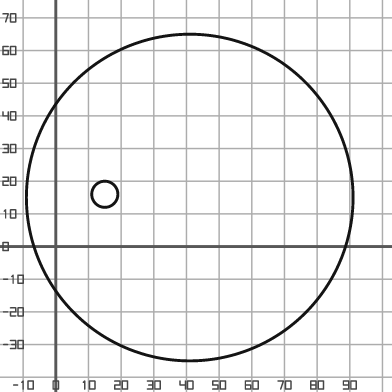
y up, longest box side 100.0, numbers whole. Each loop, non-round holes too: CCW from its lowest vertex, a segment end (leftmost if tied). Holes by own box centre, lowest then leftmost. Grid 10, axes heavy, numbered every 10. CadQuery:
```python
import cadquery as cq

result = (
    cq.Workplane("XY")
    .moveTo(41.0, 15.0)
    .circle(50.0)
    .moveTo(15.0, 16.0)
    .circle(4.0)
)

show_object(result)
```